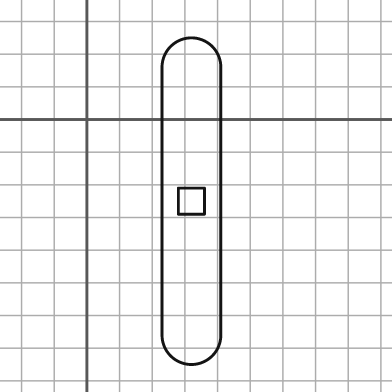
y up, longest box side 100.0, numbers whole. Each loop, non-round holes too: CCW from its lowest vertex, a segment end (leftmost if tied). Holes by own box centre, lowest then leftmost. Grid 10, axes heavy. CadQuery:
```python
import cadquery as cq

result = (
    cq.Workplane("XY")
    .moveTo(23.0, -66.0)
    .threePointArc((32.0, -75.0), (41.0, -66.0))
    .lineTo(41.0, 16.0)
    .threePointArc((32.0, 25.0), (23.0, 16.0))
    .close()
    .moveTo(28.0, -29.0)
    .lineTo(36.0, -29.0)
    .lineTo(36.0, -21.0)
    .lineTo(28.0, -21.0)
    .close()
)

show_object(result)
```